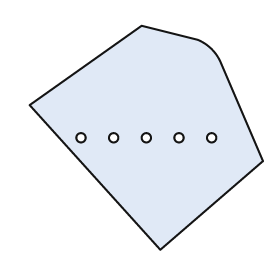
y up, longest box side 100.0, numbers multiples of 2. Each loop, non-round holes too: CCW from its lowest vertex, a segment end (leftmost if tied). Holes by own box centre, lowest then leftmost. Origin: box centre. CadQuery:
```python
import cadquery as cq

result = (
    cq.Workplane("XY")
    .moveTo(6.0, -48.0)
    .lineTo(50.0, -10.0)
    .lineTo(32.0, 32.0)
    .threePointArc((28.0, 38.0), (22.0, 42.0))
    .lineTo(-2.0, 48.0)
    .lineTo(-50.0, 14.0)
    .close()
    .moveTo(-28.0, 0.0)
    .circle(2.0)
    .moveTo(-14.0, 0.0)
    .circle(2.0)
    .moveTo(0.0, 0.0)
    .circle(2.0)
    .moveTo(14.0, 0.0)
    .circle(2.0)
    .moveTo(28.0, 0.0)
    .circle(2.0)
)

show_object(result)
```